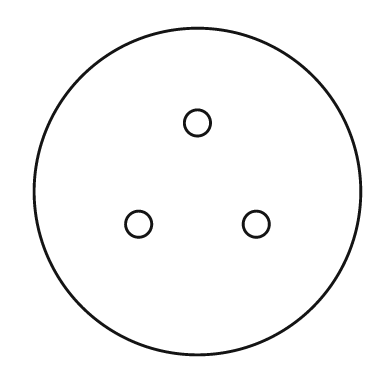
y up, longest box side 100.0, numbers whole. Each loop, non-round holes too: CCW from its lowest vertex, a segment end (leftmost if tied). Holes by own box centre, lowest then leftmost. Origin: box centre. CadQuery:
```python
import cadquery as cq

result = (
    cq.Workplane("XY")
    .moveTo(0.0, 0.0)
    .circle(50.0)
    .moveTo(-18.0, -10.0)
    .circle(4.0)
    .moveTo(18.0, -10.0)
    .circle(4.0)
    .moveTo(0.0, 21.0)
    .circle(4.0)
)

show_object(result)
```